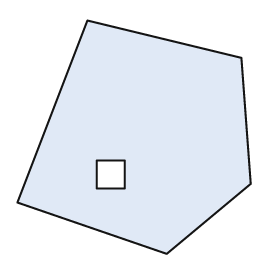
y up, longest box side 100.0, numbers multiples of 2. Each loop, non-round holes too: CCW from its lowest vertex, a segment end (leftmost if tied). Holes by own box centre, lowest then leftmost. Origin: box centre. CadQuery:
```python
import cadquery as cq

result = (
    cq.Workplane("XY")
    .moveTo(14.0, -50.0)
    .lineTo(50.0, -20.0)
    .lineTo(46.0, 34.0)
    .lineTo(-20.0, 50.0)
    .lineTo(-50.0, -28.0)
    .close()
    .moveTo(-16.0, -22.0)
    .lineTo(-4.0, -22.0)
    .lineTo(-4.0, -10.0)
    .lineTo(-16.0, -10.0)
    .close()
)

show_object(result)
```